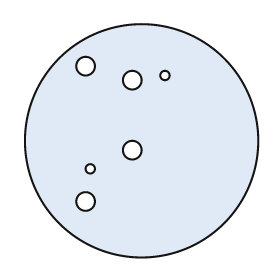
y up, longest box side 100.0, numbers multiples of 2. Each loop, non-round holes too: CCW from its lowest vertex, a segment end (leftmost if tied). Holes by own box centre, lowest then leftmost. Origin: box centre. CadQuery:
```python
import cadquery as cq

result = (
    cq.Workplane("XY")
    .moveTo(0.0, 0.0)
    .circle(50.0)
    .moveTo(-24.0, -26.0)
    .circle(4.0)
    .moveTo(-22.0, -12.0)
    .circle(2.0)
    .moveTo(-4.0, -4.0)
    .circle(4.0)
    .moveTo(-4.0, 26.0)
    .circle(4.0)
    .moveTo(10.0, 28.0)
    .circle(2.0)
    .moveTo(-24.0, 32.0)
    .circle(4.0)
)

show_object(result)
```